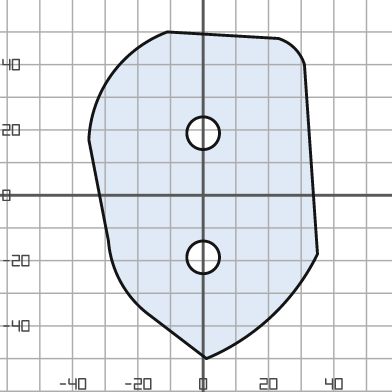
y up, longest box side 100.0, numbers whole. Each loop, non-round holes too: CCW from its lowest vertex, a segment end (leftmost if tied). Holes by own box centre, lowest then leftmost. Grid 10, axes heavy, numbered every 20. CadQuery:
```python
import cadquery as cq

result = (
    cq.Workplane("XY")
    .moveTo(1.0, -50.0)
    .threePointArc((21.0, -37.0), (35.0, -18.0))
    .lineTo(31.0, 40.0)
    .threePointArc((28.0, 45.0), (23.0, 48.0))
    .lineTo(-11.0, 50.0)
    .threePointArc((-28.0, 37.0), (-35.0, 17.0))
    .lineTo(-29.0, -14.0)
    .threePointArc((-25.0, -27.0), (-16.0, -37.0))
    .close()
    .moveTo(0.0, -19.0)
    .circle(5.0)
    .moveTo(0.0, 19.0)
    .circle(5.0)
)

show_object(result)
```